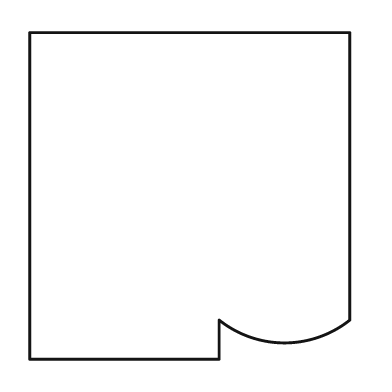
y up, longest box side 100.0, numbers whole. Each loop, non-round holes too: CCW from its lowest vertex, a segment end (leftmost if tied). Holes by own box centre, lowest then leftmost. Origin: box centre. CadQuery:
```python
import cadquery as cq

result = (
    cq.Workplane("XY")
    .moveTo(-49.0, -50.0)
    .lineTo(9.0, -50.0)
    .lineTo(9.0, -38.0)
    .threePointArc((29.0, -45.0), (49.0, -38.0))
    .lineTo(49.0, 50.0)
    .lineTo(-49.0, 50.0)
    .close()
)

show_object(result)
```